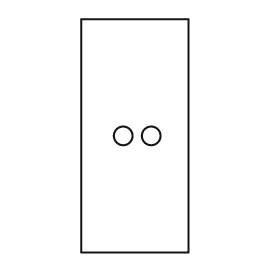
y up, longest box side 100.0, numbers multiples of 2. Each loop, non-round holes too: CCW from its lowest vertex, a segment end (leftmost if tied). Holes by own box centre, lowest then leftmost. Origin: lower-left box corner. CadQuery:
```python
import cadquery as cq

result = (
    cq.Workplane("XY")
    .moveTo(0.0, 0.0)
    .lineTo(46.0, 0.0)
    .lineTo(46.0, 100.0)
    .lineTo(0.0, 100.0)
    .close()
    .moveTo(18.0, 50.0)
    .circle(4.0)
    .moveTo(30.0, 50.0)
    .circle(4.0)
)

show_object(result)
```